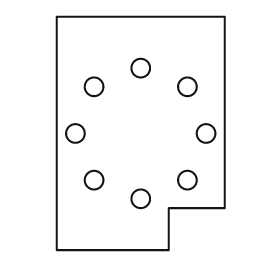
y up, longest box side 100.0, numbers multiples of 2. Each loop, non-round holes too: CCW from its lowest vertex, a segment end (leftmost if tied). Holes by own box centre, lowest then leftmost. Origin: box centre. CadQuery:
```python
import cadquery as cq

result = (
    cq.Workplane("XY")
    .moveTo(-36.0, -50.0)
    .lineTo(12.0, -50.0)
    .lineTo(12.0, -32.0)
    .lineTo(36.0, -32.0)
    .lineTo(36.0, 50.0)
    .lineTo(-36.0, 50.0)
    .close()
    .moveTo(0.0, -28.0)
    .circle(4.0)
    .moveTo(-20.0, -20.0)
    .circle(4.0)
    .moveTo(20.0, -20.0)
    .circle(4.0)
    .moveTo(-28.0, 0.0)
    .circle(4.0)
    .moveTo(28.0, 0.0)
    .circle(4.0)
    .moveTo(-20.0, 20.0)
    .circle(4.0)
    .moveTo(20.0, 20.0)
    .circle(4.0)
    .moveTo(0.0, 28.0)
    .circle(4.0)
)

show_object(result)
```